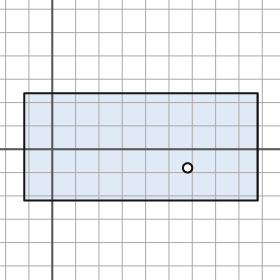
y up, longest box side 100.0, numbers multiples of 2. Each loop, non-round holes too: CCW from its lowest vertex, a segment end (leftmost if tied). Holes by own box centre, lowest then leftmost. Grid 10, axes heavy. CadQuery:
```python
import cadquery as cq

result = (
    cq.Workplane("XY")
    .moveTo(-12.0, -22.0)
    .lineTo(88.0, -22.0)
    .lineTo(88.0, 24.0)
    .lineTo(-12.0, 24.0)
    .close()
    .moveTo(58.0, -8.0)
    .circle(2.0)
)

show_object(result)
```